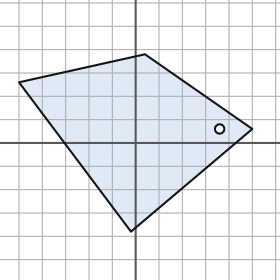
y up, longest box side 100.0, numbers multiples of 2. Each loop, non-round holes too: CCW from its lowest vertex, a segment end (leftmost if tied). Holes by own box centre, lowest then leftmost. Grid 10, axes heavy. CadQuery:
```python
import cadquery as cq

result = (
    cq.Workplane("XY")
    .moveTo(-2.0, -38.0)
    .lineTo(50.0, 6.0)
    .lineTo(4.0, 38.0)
    .lineTo(-50.0, 26.0)
    .close()
    .moveTo(36.0, 6.0)
    .circle(2.0)
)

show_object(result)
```